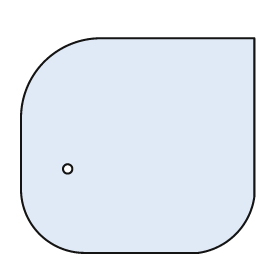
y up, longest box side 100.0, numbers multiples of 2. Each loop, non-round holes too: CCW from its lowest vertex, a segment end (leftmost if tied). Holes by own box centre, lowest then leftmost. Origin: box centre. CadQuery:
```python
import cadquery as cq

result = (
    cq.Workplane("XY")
    .moveTo(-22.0, -46.0)
    .lineTo(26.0, -46.0)
    .threePointArc((42.0, -38.0), (50.0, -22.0))
    .lineTo(50.0, 46.0)
    .lineTo(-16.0, 46.0)
    .threePointArc((-40.0, 36.0), (-50.0, 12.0))
    .lineTo(-50.0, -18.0)
    .threePointArc((-42.0, -38.0), (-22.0, -46.0))
    .close()
    .moveTo(-30.0, -10.0)
    .circle(2.0)
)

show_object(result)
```